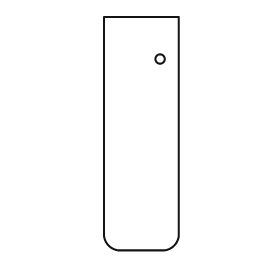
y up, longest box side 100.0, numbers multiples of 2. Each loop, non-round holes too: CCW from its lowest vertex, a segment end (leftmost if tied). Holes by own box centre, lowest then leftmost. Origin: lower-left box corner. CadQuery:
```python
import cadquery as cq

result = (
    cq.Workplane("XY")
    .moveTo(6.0, 0.0)
    .lineTo(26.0, 0.0)
    .threePointArc((30.0, 2.0), (32.0, 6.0))
    .lineTo(32.0, 100.0)
    .lineTo(0.0, 100.0)
    .lineTo(0.0, 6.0)
    .threePointArc((2.0, 2.0), (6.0, 0.0))
    .close()
    .moveTo(24.0, 82.0)
    .circle(2.0)
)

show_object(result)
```